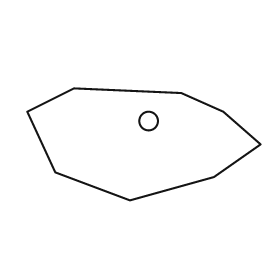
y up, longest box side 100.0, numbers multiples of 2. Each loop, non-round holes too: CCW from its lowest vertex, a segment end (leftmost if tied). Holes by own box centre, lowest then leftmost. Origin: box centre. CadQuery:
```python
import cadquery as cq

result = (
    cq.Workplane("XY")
    .moveTo(-6.0, -24.0)
    .lineTo(30.0, -14.0)
    .lineTo(50.0, 0.0)
    .lineTo(34.0, 14.0)
    .lineTo(16.0, 22.0)
    .lineTo(-30.0, 24.0)
    .lineTo(-50.0, 14.0)
    .lineTo(-38.0, -12.0)
    .close()
    .moveTo(2.0, 10.0)
    .circle(4.0)
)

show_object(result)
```